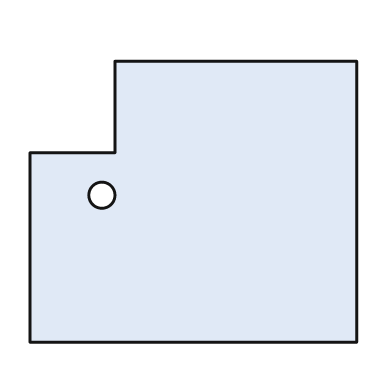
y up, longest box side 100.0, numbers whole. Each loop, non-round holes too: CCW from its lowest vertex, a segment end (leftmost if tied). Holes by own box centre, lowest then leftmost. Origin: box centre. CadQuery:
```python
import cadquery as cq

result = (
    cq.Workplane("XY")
    .moveTo(-50.0, -43.0)
    .lineTo(50.0, -43.0)
    .lineTo(50.0, 43.0)
    .lineTo(-24.0, 43.0)
    .lineTo(-24.0, 15.0)
    .lineTo(-50.0, 15.0)
    .close()
    .moveTo(-28.0, 2.0)
    .circle(4.0)
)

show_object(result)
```